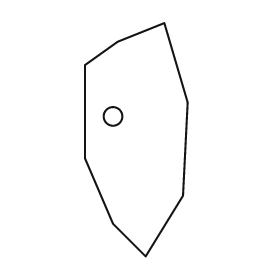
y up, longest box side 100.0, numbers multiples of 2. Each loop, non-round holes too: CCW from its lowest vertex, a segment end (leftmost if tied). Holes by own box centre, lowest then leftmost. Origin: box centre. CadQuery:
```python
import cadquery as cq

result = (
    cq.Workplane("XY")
    .moveTo(4.0, -50.0)
    .lineTo(20.0, -24.0)
    .lineTo(22.0, 16.0)
    .lineTo(12.0, 50.0)
    .lineTo(-8.0, 42.0)
    .lineTo(-22.0, 32.0)
    .lineTo(-22.0, -8.0)
    .lineTo(-10.0, -36.0)
    .close()
    .moveTo(-10.0, 10.0)
    .circle(4.0)
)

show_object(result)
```